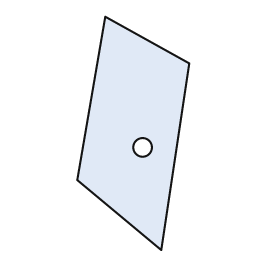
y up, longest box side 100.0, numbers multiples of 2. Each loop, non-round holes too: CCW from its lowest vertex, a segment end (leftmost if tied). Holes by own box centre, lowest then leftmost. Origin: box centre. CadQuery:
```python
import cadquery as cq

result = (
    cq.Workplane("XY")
    .moveTo(12.0, -50.0)
    .lineTo(24.0, 30.0)
    .lineTo(-12.0, 50.0)
    .lineTo(-24.0, -20.0)
    .close()
    .moveTo(4.0, -6.0)
    .circle(4.0)
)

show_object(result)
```